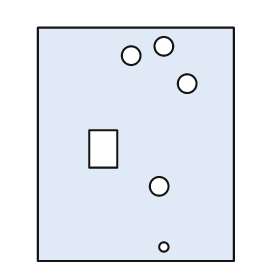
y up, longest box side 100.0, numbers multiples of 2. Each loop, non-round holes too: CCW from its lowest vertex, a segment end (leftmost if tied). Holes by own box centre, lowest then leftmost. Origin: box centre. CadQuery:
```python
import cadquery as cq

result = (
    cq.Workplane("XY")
    .moveTo(-42.0, -50.0)
    .lineTo(42.0, -50.0)
    .lineTo(42.0, 50.0)
    .lineTo(-42.0, 50.0)
    .close()
    .moveTo(12.0, -44.0)
    .circle(2.0)
    .moveTo(10.0, -18.0)
    .circle(4.0)
    .moveTo(-20.0, -10.0)
    .lineTo(-8.0, -10.0)
    .lineTo(-8.0, 6.0)
    .lineTo(-20.0, 6.0)
    .close()
    .moveTo(22.0, 26.0)
    .circle(4.0)
    .moveTo(-2.0, 38.0)
    .circle(4.0)
    .moveTo(12.0, 42.0)
    .circle(4.0)
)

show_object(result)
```